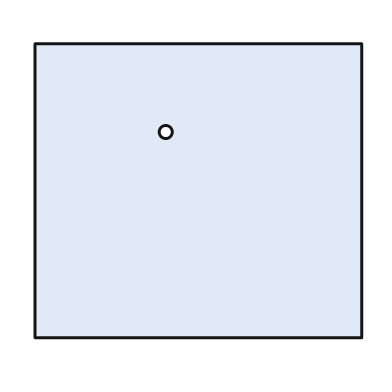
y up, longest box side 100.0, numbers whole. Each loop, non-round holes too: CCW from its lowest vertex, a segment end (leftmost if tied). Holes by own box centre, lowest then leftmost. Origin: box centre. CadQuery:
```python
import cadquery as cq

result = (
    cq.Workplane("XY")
    .moveTo(-50.0, -45.0)
    .lineTo(50.0, -45.0)
    .lineTo(50.0, 45.0)
    .lineTo(-50.0, 45.0)
    .close()
    .moveTo(-10.0, 18.0)
    .circle(2.0)
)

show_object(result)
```